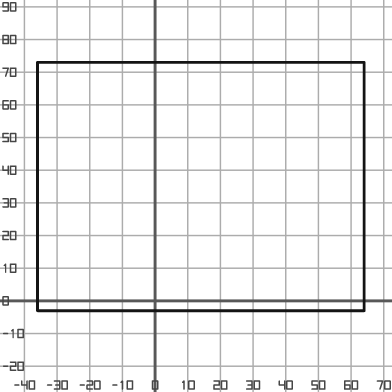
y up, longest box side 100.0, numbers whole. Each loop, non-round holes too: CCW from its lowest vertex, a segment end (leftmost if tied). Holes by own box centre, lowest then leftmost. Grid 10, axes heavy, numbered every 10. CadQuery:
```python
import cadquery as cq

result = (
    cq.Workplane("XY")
    .moveTo(-36.0, -3.0)
    .lineTo(64.0, -3.0)
    .lineTo(64.0, 73.0)
    .lineTo(-36.0, 73.0)
    .close()
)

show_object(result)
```